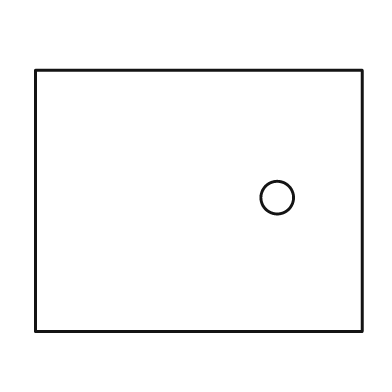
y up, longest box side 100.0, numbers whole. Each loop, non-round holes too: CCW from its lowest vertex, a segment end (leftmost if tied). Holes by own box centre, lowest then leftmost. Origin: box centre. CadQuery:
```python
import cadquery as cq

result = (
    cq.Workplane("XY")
    .moveTo(-50.0, -40.0)
    .lineTo(50.0, -40.0)
    .lineTo(50.0, 40.0)
    .lineTo(-50.0, 40.0)
    .close()
    .moveTo(24.0, 1.0)
    .circle(5.0)
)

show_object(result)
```